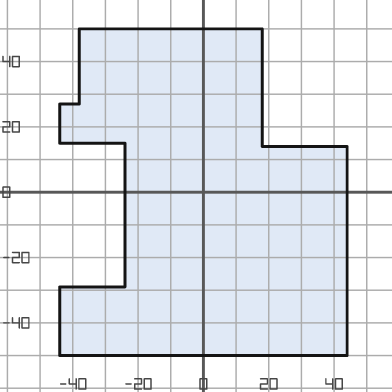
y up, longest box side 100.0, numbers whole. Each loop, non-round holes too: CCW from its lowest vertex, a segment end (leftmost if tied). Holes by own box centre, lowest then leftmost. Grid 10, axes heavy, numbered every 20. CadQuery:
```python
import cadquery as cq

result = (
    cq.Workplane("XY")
    .moveTo(-44.0, -50.0)
    .lineTo(44.0, -50.0)
    .lineTo(44.0, 14.0)
    .lineTo(18.0, 14.0)
    .lineTo(18.0, 50.0)
    .lineTo(-38.0, 50.0)
    .lineTo(-38.0, 27.0)
    .lineTo(-44.0, 27.0)
    .lineTo(-44.0, 15.0)
    .lineTo(-24.0, 15.0)
    .lineTo(-24.0, -29.0)
    .lineTo(-44.0, -29.0)
    .close()
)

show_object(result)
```